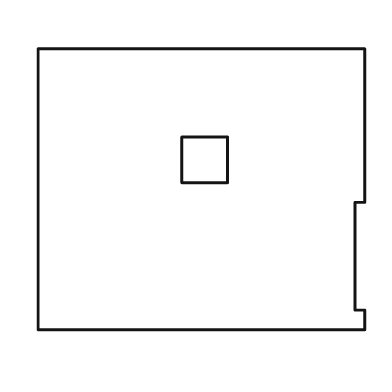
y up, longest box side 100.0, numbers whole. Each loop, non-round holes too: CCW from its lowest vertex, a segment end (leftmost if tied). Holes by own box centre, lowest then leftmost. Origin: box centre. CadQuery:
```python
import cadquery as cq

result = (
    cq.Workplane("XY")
    .moveTo(-50.0, -43.0)
    .lineTo(50.0, -43.0)
    .lineTo(50.0, -37.0)
    .lineTo(47.0, -37.0)
    .lineTo(47.0, -4.0)
    .lineTo(50.0, -4.0)
    .lineTo(50.0, 43.0)
    .lineTo(-50.0, 43.0)
    .close()
    .moveTo(-6.0, 2.0)
    .lineTo(8.0, 2.0)
    .lineTo(8.0, 16.0)
    .lineTo(-6.0, 16.0)
    .close()
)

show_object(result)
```